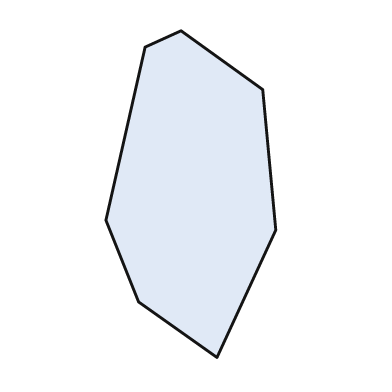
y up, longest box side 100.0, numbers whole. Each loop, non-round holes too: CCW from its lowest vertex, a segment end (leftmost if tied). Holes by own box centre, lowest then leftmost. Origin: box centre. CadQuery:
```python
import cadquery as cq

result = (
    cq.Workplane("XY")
    .moveTo(8.0, -50.0)
    .lineTo(26.0, -11.0)
    .lineTo(22.0, 32.0)
    .lineTo(-3.0, 50.0)
    .lineTo(-14.0, 45.0)
    .lineTo(-26.0, -8.0)
    .lineTo(-16.0, -33.0)
    .close()
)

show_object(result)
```